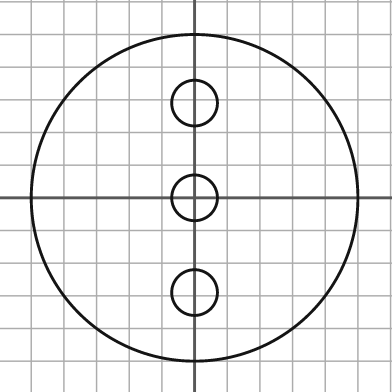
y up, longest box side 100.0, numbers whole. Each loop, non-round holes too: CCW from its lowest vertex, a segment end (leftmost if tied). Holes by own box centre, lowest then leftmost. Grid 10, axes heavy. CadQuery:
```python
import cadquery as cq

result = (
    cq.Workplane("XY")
    .moveTo(0.0, 0.0)
    .circle(50.0)
    .moveTo(0.0, -29.0)
    .circle(7.0)
    .moveTo(0.0, 0.0)
    .circle(7.0)
    .moveTo(0.0, 29.0)
    .circle(7.0)
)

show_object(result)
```